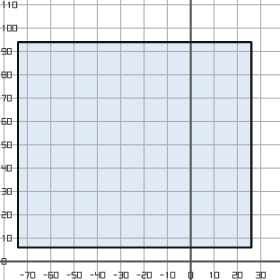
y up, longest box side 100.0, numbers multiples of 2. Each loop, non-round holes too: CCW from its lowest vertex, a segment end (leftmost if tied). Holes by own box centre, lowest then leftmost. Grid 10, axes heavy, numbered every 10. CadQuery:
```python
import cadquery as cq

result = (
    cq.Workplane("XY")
    .moveTo(-74.0, 6.0)
    .lineTo(26.0, 6.0)
    .lineTo(26.0, 94.0)
    .lineTo(-74.0, 94.0)
    .close()
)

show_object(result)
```